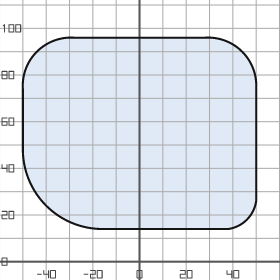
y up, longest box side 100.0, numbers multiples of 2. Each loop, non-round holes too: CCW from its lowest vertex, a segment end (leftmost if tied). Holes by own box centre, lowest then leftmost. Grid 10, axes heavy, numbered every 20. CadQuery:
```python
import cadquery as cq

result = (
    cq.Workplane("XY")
    .moveTo(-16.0, 14.0)
    .lineTo(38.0, 14.0)
    .threePointArc((46.0, 18.0), (50.0, 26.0))
    .lineTo(50.0, 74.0)
    .threePointArc((44.0, 90.0), (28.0, 96.0))
    .lineTo(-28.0, 96.0)
    .threePointArc((-44.0, 90.0), (-50.0, 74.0))
    .lineTo(-50.0, 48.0)
    .threePointArc((-40.0, 24.0), (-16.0, 14.0))
    .close()
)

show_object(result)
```